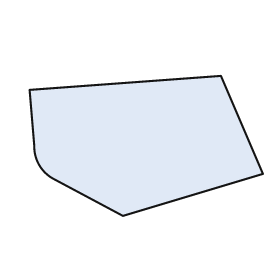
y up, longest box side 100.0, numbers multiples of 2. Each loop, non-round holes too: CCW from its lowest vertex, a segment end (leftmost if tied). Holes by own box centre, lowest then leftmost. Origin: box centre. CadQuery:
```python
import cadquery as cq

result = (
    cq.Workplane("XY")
    .moveTo(-10.0, -30.0)
    .lineTo(50.0, -12.0)
    .lineTo(32.0, 30.0)
    .lineTo(-50.0, 24.0)
    .lineTo(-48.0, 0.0)
    .threePointArc((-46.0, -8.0), (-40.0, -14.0))
    .close()
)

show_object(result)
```